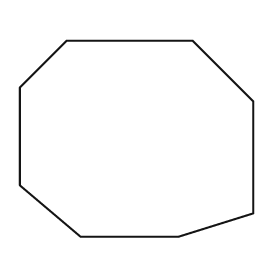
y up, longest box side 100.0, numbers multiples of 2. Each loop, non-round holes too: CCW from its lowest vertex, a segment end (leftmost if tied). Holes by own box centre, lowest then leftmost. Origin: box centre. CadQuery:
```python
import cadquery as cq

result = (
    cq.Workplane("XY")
    .moveTo(-24.0, -42.0)
    .lineTo(18.0, -42.0)
    .lineTo(50.0, -32.0)
    .lineTo(50.0, 16.0)
    .lineTo(24.0, 42.0)
    .lineTo(-30.0, 42.0)
    .lineTo(-50.0, 22.0)
    .lineTo(-50.0, -20.0)
    .close()
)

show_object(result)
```